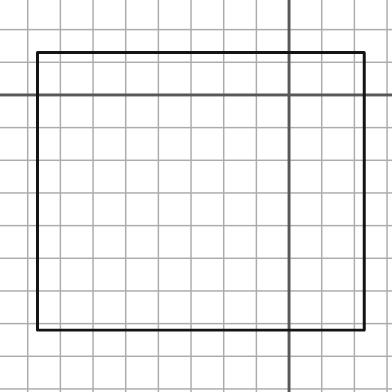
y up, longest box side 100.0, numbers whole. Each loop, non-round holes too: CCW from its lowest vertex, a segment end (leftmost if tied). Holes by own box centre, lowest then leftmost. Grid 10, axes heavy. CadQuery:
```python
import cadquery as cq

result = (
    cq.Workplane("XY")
    .moveTo(-77.0, -72.0)
    .lineTo(23.0, -72.0)
    .lineTo(23.0, 13.0)
    .lineTo(-77.0, 13.0)
    .close()
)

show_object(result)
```